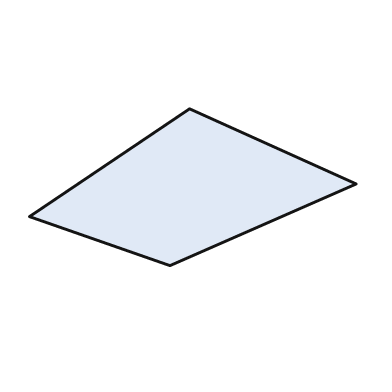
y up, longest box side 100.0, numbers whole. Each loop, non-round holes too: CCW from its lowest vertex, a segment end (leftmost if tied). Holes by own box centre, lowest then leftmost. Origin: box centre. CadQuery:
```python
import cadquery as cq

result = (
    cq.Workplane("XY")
    .moveTo(-7.0, -24.0)
    .lineTo(50.0, 1.0)
    .lineTo(-1.0, 24.0)
    .lineTo(-50.0, -9.0)
    .close()
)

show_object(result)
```